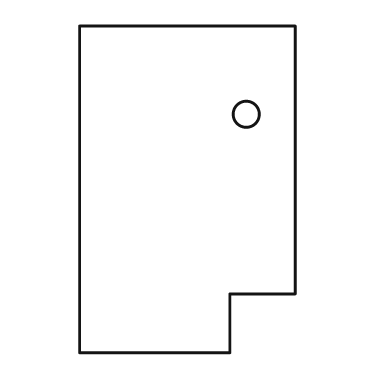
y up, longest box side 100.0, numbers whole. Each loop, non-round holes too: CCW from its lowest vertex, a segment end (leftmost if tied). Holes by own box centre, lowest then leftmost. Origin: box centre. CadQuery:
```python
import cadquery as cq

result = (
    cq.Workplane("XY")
    .moveTo(-33.0, -50.0)
    .lineTo(13.0, -50.0)
    .lineTo(13.0, -32.0)
    .lineTo(33.0, -32.0)
    .lineTo(33.0, 50.0)
    .lineTo(-33.0, 50.0)
    .close()
    .moveTo(18.0, 23.0)
    .circle(4.0)
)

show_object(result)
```